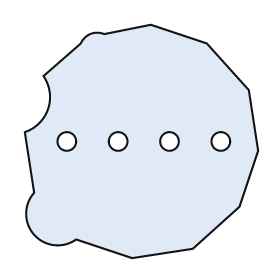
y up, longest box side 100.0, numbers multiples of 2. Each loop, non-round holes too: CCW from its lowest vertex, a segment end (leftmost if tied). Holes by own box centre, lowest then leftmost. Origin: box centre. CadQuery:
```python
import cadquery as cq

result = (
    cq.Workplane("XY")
    .moveTo(-4.0, -50.0)
    .lineTo(22.0, -46.0)
    .lineTo(42.0, -28.0)
    .lineTo(50.0, -4.0)
    .lineTo(46.0, 22.0)
    .lineTo(28.0, 42.0)
    .lineTo(4.0, 50.0)
    .lineTo(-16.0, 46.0)
    .threePointArc((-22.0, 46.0), (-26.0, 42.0))
    .lineTo(-42.0, 28.0)
    .threePointArc((-40.0, 14.0), (-50.0, 4.0))
    .lineTo(-46.0, -22.0)
    .threePointArc((-46.0, -40.0), (-28.0, -42.0))
    .close()
    .moveTo(-32.0, 0.0)
    .circle(4.0)
    .moveTo(-10.0, 0.0)
    .circle(4.0)
    .moveTo(12.0, 0.0)
    .circle(4.0)
    .moveTo(34.0, 0.0)
    .circle(4.0)
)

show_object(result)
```